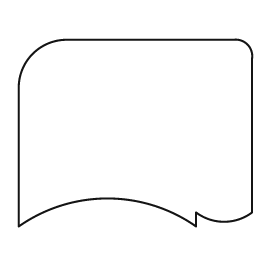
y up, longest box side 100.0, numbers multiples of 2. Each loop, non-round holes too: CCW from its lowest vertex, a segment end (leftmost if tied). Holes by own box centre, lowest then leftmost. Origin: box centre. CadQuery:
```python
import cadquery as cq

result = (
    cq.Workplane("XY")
    .moveTo(-50.0, -40.0)
    .threePointArc((-12.0, -28.0), (26.0, -40.0))
    .lineTo(26.0, -34.0)
    .threePointArc((38.0, -38.0), (50.0, -34.0))
    .lineTo(50.0, 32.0)
    .threePointArc((48.0, 38.0), (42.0, 40.0))
    .lineTo(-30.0, 40.0)
    .threePointArc((-44.0, 34.0), (-50.0, 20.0))
    .close()
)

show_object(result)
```